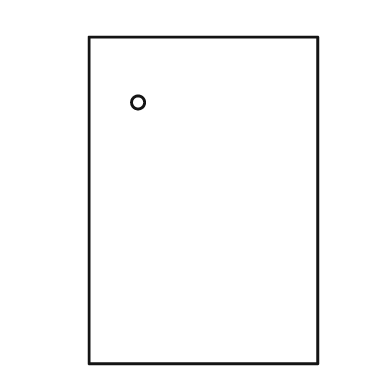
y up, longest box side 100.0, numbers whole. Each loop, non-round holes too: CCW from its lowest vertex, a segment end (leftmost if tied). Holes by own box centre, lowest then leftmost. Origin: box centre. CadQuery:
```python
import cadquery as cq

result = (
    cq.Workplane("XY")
    .moveTo(-35.0, -50.0)
    .lineTo(35.0, -50.0)
    .lineTo(35.0, 50.0)
    .lineTo(-35.0, 50.0)
    .close()
    .moveTo(-20.0, 30.0)
    .circle(2.0)
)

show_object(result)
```